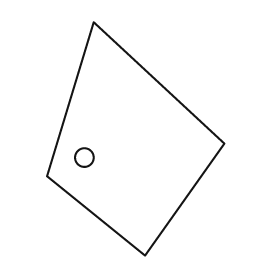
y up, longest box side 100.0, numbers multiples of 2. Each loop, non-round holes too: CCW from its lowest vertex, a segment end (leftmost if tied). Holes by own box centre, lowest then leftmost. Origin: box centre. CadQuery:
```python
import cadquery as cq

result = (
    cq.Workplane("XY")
    .moveTo(4.0, -50.0)
    .lineTo(38.0, -2.0)
    .lineTo(-18.0, 50.0)
    .lineTo(-38.0, -16.0)
    .close()
    .moveTo(-22.0, -8.0)
    .circle(4.0)
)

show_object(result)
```